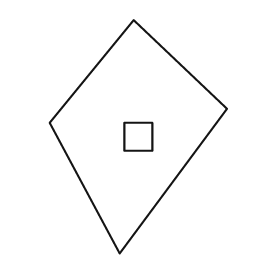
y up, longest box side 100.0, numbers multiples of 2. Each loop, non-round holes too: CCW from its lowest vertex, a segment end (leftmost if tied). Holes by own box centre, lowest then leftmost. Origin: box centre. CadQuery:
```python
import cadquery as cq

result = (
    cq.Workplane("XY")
    .moveTo(-8.0, -50.0)
    .lineTo(38.0, 12.0)
    .lineTo(-2.0, 50.0)
    .lineTo(-38.0, 6.0)
    .close()
    .moveTo(-6.0, -6.0)
    .lineTo(6.0, -6.0)
    .lineTo(6.0, 6.0)
    .lineTo(-6.0, 6.0)
    .close()
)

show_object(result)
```